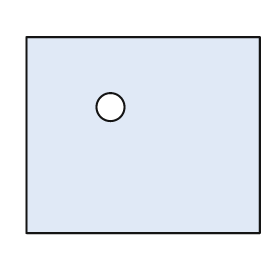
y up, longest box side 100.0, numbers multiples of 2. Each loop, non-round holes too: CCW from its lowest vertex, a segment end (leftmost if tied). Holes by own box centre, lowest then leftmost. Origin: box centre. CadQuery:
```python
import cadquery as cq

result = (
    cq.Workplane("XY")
    .moveTo(-50.0, -42.0)
    .lineTo(50.0, -42.0)
    .lineTo(50.0, 42.0)
    .lineTo(-50.0, 42.0)
    .close()
    .moveTo(-14.0, 12.0)
    .circle(6.0)
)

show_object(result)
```